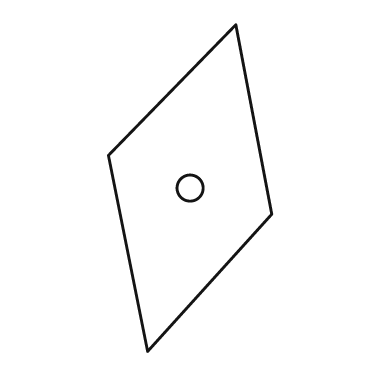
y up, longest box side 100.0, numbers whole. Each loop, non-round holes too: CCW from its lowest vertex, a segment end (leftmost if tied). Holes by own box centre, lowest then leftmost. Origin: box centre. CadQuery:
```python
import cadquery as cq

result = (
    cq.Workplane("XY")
    .moveTo(-13.0, -50.0)
    .lineTo(25.0, -8.0)
    .lineTo(14.0, 50.0)
    .lineTo(-25.0, 10.0)
    .close()
    .moveTo(0.0, 0.0)
    .circle(4.0)
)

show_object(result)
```